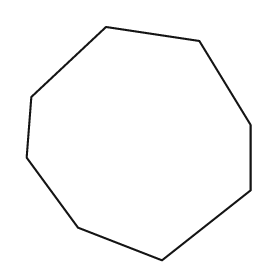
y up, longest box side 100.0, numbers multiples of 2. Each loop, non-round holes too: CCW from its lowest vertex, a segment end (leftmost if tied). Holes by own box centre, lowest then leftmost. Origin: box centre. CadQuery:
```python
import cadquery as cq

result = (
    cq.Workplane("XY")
    .moveTo(10.0, -50.0)
    .lineTo(48.0, -20.0)
    .lineTo(48.0, 8.0)
    .lineTo(26.0, 44.0)
    .lineTo(-14.0, 50.0)
    .lineTo(-46.0, 20.0)
    .lineTo(-48.0, -6.0)
    .lineTo(-26.0, -36.0)
    .close()
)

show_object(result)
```